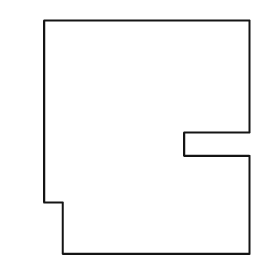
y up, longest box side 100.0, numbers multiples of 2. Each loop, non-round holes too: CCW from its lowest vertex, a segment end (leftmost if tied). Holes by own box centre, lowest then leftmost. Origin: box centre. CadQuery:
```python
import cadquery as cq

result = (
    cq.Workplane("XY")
    .moveTo(-36.0, -50.0)
    .lineTo(44.0, -50.0)
    .lineTo(44.0, -8.0)
    .lineTo(16.0, -8.0)
    .lineTo(16.0, 2.0)
    .lineTo(44.0, 2.0)
    .lineTo(44.0, 50.0)
    .lineTo(-44.0, 50.0)
    .lineTo(-44.0, -28.0)
    .lineTo(-36.0, -28.0)
    .close()
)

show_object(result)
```